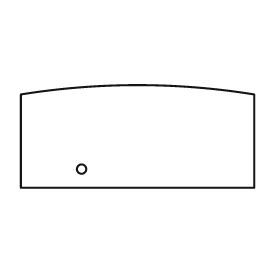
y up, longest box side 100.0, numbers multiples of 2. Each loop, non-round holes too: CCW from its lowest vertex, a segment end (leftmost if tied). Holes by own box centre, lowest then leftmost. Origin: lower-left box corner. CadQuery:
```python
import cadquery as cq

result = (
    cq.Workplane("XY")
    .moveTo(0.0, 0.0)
    .lineTo(100.0, 0.0)
    .lineTo(100.0, 40.0)
    .threePointArc((50.0, 44.0), (0.0, 40.0))
    .close()
    .moveTo(26.0, 8.0)
    .circle(2.0)
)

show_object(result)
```